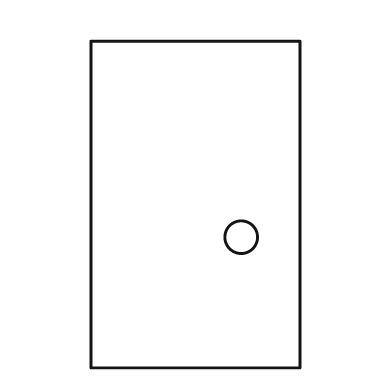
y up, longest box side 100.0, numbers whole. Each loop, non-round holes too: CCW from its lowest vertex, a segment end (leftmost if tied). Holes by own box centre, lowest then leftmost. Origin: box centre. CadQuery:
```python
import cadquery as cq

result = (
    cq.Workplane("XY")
    .moveTo(-32.0, -50.0)
    .lineTo(32.0, -50.0)
    .lineTo(32.0, 50.0)
    .lineTo(-32.0, 50.0)
    .close()
    .moveTo(14.0, -10.0)
    .circle(5.0)
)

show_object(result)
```